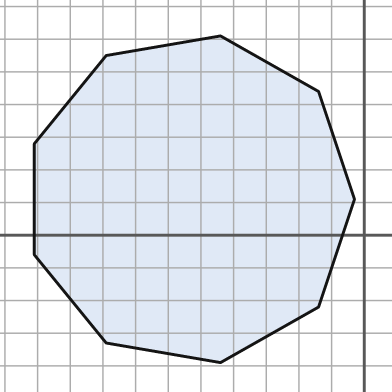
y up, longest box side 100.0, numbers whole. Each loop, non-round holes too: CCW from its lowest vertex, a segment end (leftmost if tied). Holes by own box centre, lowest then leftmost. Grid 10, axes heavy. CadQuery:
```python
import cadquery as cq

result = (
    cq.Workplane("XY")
    .moveTo(-44.0, -39.0)
    .lineTo(-14.0, -22.0)
    .lineTo(-3.0, 11.0)
    .lineTo(-14.0, 44.0)
    .lineTo(-44.0, 61.0)
    .lineTo(-79.0, 55.0)
    .lineTo(-101.0, 28.0)
    .lineTo(-101.0, -6.0)
    .lineTo(-79.0, -33.0)
    .close()
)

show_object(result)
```